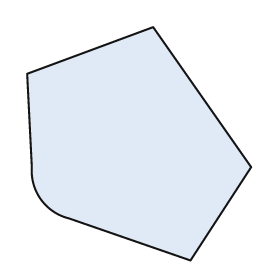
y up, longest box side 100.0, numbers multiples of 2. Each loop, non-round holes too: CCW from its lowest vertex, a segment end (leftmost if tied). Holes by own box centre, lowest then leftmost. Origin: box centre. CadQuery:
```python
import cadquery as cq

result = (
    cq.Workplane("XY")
    .moveTo(22.0, -50.0)
    .lineTo(48.0, -10.0)
    .lineTo(6.0, 50.0)
    .lineTo(-48.0, 30.0)
    .lineTo(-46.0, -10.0)
    .threePointArc((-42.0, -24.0), (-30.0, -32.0))
    .close()
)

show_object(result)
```